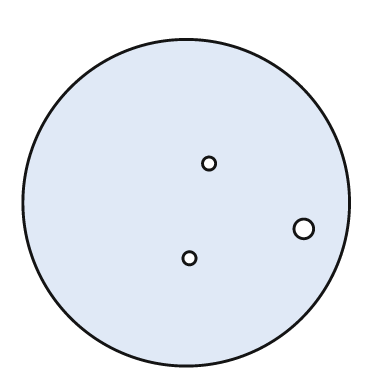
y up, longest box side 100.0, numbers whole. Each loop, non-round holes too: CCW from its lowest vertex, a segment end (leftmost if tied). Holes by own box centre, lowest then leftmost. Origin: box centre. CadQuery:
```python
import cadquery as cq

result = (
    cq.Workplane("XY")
    .moveTo(0.0, 0.0)
    .circle(50.0)
    .moveTo(1.0, -17.0)
    .circle(2.0)
    .moveTo(36.0, -8.0)
    .circle(3.0)
    .moveTo(7.0, 12.0)
    .circle(2.0)
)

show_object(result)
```